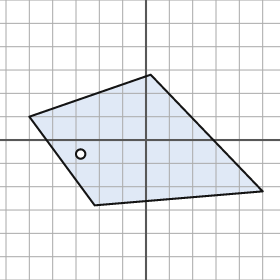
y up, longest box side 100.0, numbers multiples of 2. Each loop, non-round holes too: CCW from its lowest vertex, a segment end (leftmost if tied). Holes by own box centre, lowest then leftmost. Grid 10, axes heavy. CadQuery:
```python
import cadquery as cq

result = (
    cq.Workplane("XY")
    .moveTo(-22.0, -28.0)
    .lineTo(50.0, -22.0)
    .lineTo(2.0, 28.0)
    .lineTo(-50.0, 10.0)
    .close()
    .moveTo(-28.0, -6.0)
    .circle(2.0)
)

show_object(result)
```